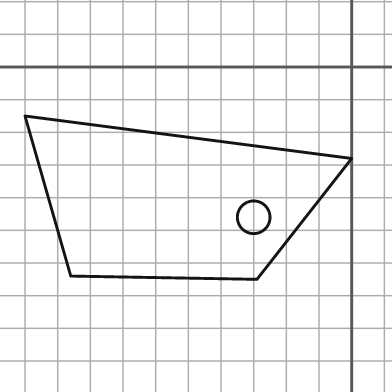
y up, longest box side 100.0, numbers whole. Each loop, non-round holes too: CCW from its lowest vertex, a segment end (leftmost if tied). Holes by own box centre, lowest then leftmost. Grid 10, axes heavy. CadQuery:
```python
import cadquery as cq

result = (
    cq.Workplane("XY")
    .moveTo(-29.0, -65.0)
    .lineTo(0.0, -28.0)
    .lineTo(-100.0, -15.0)
    .lineTo(-86.0, -64.0)
    .close()
    .moveTo(-30.0, -46.0)
    .circle(5.0)
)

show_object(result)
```